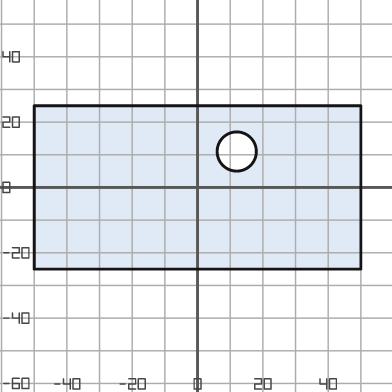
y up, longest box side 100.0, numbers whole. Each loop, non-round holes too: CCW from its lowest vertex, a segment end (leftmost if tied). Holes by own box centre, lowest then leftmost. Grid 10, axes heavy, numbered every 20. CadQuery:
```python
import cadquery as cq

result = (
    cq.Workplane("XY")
    .moveTo(-50.0, -25.0)
    .lineTo(50.0, -25.0)
    .lineTo(50.0, 25.0)
    .lineTo(-50.0, 25.0)
    .close()
    .moveTo(12.0, 11.0)
    .circle(6.0)
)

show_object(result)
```